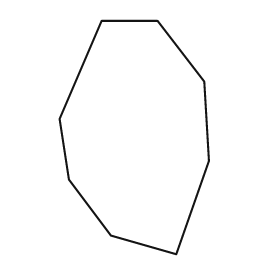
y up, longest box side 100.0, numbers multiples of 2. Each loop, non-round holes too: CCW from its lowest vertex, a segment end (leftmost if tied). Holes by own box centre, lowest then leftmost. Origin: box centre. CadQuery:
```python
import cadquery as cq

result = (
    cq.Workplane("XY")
    .moveTo(18.0, -50.0)
    .lineTo(32.0, -10.0)
    .lineTo(30.0, 24.0)
    .lineTo(10.0, 50.0)
    .lineTo(-14.0, 50.0)
    .lineTo(-32.0, 8.0)
    .lineTo(-28.0, -18.0)
    .lineTo(-10.0, -42.0)
    .close()
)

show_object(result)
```